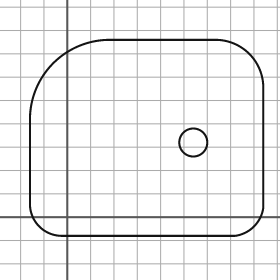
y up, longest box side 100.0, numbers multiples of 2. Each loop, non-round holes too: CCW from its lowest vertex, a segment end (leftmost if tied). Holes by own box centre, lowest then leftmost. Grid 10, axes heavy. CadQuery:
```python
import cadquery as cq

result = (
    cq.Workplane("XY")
    .moveTo(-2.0, -8.0)
    .lineTo(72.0, -8.0)
    .threePointArc((80.0, -4.0), (84.0, 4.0))
    .lineTo(84.0, 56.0)
    .threePointArc((78.0, 70.0), (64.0, 76.0))
    .lineTo(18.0, 76.0)
    .threePointArc((-6.0, 66.0), (-16.0, 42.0))
    .lineTo(-16.0, 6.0)
    .threePointArc((-12.0, -4.0), (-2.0, -8.0))
    .close()
    .moveTo(54.0, 32.0)
    .circle(6.0)
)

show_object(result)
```